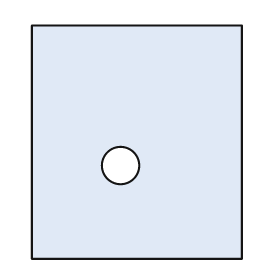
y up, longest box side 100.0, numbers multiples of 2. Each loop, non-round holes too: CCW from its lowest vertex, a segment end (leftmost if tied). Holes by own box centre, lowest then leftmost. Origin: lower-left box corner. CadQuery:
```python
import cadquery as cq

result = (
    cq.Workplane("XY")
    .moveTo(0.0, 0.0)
    .lineTo(90.0, 0.0)
    .lineTo(90.0, 100.0)
    .lineTo(0.0, 100.0)
    .close()
    .moveTo(38.0, 40.0)
    .circle(8.0)
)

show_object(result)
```